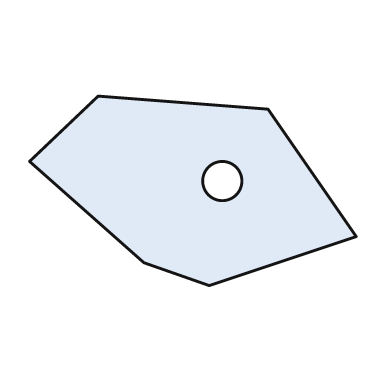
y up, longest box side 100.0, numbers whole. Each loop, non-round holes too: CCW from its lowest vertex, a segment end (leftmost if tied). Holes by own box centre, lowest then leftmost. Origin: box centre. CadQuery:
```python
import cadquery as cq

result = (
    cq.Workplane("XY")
    .moveTo(5.0, -29.0)
    .lineTo(50.0, -14.0)
    .lineTo(23.0, 25.0)
    .lineTo(-29.0, 29.0)
    .lineTo(-50.0, 9.0)
    .lineTo(-15.0, -22.0)
    .close()
    .moveTo(9.0, 3.0)
    .circle(6.0)
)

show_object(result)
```